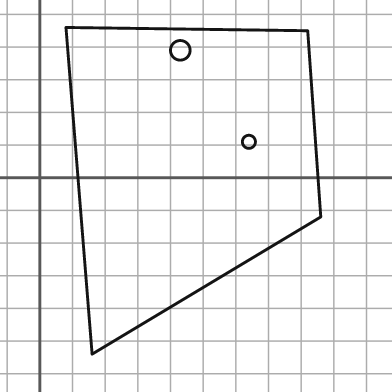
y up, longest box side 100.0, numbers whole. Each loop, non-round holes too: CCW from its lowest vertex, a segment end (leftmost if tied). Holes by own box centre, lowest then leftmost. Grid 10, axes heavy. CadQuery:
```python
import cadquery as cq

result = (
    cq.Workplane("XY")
    .moveTo(16.0, -54.0)
    .lineTo(86.0, -12.0)
    .lineTo(82.0, 45.0)
    .lineTo(8.0, 46.0)
    .close()
    .moveTo(64.0, 11.0)
    .circle(2.0)
    .moveTo(43.0, 39.0)
    .circle(3.0)
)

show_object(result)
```